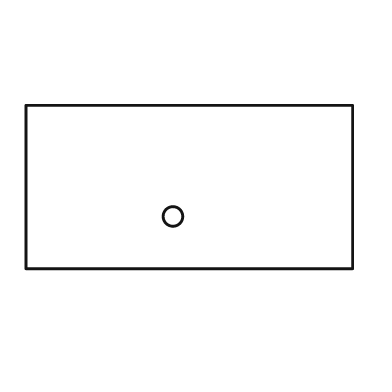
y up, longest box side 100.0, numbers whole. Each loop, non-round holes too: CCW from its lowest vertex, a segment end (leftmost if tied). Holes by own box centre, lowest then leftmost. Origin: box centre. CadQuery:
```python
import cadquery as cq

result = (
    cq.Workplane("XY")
    .moveTo(-50.0, -25.0)
    .lineTo(50.0, -25.0)
    .lineTo(50.0, 25.0)
    .lineTo(-50.0, 25.0)
    .close()
    .moveTo(-5.0, -9.0)
    .circle(3.0)
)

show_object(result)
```